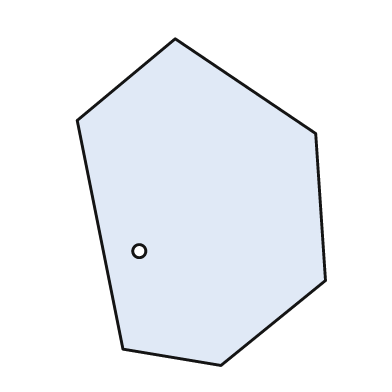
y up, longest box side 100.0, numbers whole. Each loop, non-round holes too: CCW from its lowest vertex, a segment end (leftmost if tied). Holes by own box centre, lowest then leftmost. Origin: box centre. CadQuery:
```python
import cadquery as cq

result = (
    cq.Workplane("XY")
    .moveTo(6.0, -50.0)
    .lineTo(38.0, -24.0)
    .lineTo(35.0, 21.0)
    .lineTo(-8.0, 50.0)
    .lineTo(-38.0, 25.0)
    .lineTo(-24.0, -45.0)
    .close()
    .moveTo(-19.0, -15.0)
    .circle(2.0)
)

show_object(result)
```